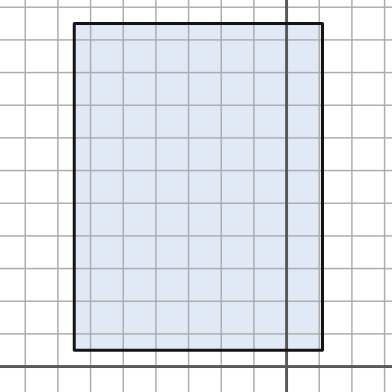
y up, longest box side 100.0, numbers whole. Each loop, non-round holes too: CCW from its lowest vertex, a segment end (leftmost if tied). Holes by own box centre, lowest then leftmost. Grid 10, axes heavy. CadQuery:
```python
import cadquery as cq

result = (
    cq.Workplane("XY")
    .moveTo(-65.0, 5.0)
    .lineTo(11.0, 5.0)
    .lineTo(11.0, 105.0)
    .lineTo(-65.0, 105.0)
    .close()
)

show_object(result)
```